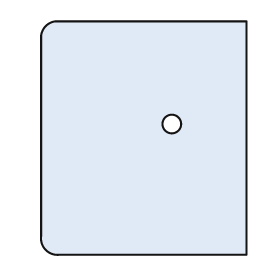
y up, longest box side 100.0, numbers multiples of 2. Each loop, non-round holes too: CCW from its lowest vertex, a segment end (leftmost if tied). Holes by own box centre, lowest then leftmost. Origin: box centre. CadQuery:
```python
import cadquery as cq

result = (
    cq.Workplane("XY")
    .moveTo(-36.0, -50.0)
    .lineTo(44.0, -50.0)
    .lineTo(44.0, 50.0)
    .lineTo(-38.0, 50.0)
    .threePointArc((-42.0, 48.0), (-44.0, 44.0))
    .lineTo(-44.0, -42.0)
    .threePointArc((-42.0, -48.0), (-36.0, -50.0))
    .close()
    .moveTo(12.0, 6.0)
    .circle(4.0)
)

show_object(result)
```